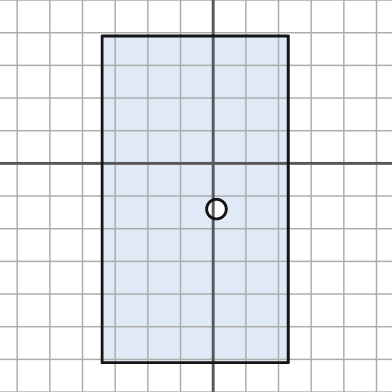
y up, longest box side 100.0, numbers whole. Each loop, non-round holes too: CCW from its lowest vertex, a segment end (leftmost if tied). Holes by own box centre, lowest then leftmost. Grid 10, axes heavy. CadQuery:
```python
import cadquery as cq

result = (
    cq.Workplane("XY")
    .moveTo(-34.0, -61.0)
    .lineTo(23.0, -61.0)
    .lineTo(23.0, 39.0)
    .lineTo(-34.0, 39.0)
    .close()
    .moveTo(1.0, -14.0)
    .circle(3.0)
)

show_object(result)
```